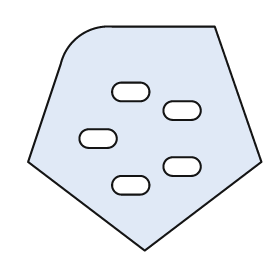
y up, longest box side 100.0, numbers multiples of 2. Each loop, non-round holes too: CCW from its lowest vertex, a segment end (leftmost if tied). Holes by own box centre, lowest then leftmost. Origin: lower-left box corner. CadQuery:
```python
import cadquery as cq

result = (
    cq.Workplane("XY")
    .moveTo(50.0, 0.0)
    .lineTo(100.0, 38.0)
    .lineTo(80.0, 96.0)
    .lineTo(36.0, 96.0)
    .threePointArc((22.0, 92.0), (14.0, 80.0))
    .lineTo(0.0, 38.0)
    .close()
    .moveTo(40.0, 24.0)
    .lineTo(48.0, 24.0)
    .threePointArc((52.0, 28.0), (48.0, 32.0))
    .lineTo(40.0, 32.0)
    .threePointArc((36.0, 28.0), (40.0, 24.0))
    .close()
    .moveTo(62.0, 32.0)
    .lineTo(70.0, 32.0)
    .threePointArc((74.0, 36.0), (70.0, 40.0))
    .lineTo(62.0, 40.0)
    .threePointArc((58.0, 36.0), (62.0, 32.0))
    .close()
    .moveTo(26.0, 44.0)
    .lineTo(34.0, 44.0)
    .threePointArc((38.0, 48.0), (34.0, 52.0))
    .lineTo(26.0, 52.0)
    .threePointArc((22.0, 48.0), (26.0, 44.0))
    .close()
    .moveTo(62.0, 56.0)
    .lineTo(70.0, 56.0)
    .threePointArc((74.0, 60.0), (70.0, 64.0))
    .lineTo(62.0, 64.0)
    .threePointArc((58.0, 60.0), (62.0, 56.0))
    .close()
    .moveTo(40.0, 64.0)
    .lineTo(48.0, 64.0)
    .threePointArc((52.0, 68.0), (48.0, 72.0))
    .lineTo(40.0, 72.0)
    .threePointArc((36.0, 68.0), (40.0, 64.0))
    .close()
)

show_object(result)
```